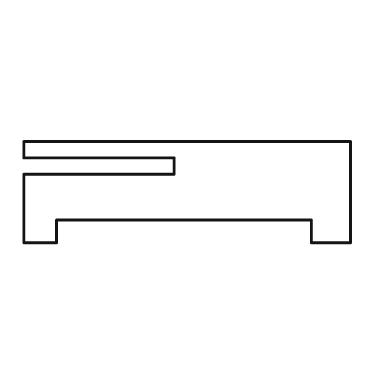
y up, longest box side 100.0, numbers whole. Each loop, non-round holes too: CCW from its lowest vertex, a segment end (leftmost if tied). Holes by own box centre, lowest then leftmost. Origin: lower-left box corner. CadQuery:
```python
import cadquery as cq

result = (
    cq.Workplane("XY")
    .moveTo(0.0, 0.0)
    .lineTo(10.0, 0.0)
    .lineTo(10.0, 7.0)
    .lineTo(88.0, 7.0)
    .lineTo(88.0, 0.0)
    .lineTo(100.0, 0.0)
    .lineTo(100.0, 31.0)
    .lineTo(0.0, 31.0)
    .lineTo(0.0, 26.0)
    .lineTo(46.0, 26.0)
    .lineTo(46.0, 21.0)
    .lineTo(0.0, 21.0)
    .close()
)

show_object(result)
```